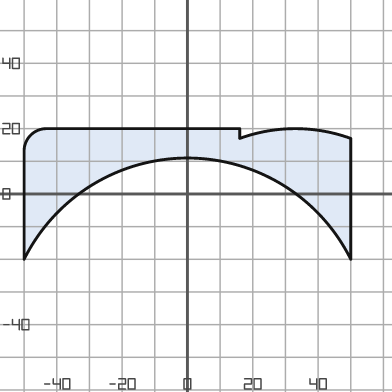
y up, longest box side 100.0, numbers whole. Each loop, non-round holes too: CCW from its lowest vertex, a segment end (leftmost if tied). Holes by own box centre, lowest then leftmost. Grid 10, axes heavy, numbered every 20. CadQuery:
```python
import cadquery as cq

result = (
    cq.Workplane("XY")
    .moveTo(-50.0, -20.0)
    .threePointArc((0.0, 11.0), (50.0, -20.0))
    .lineTo(50.0, 17.0)
    .threePointArc((33.0, 20.0), (16.0, 17.0))
    .lineTo(16.0, 20.0)
    .lineTo(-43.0, 20.0)
    .threePointArc((-48.0, 18.0), (-50.0, 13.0))
    .close()
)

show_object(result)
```